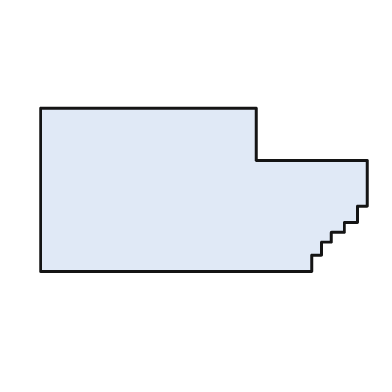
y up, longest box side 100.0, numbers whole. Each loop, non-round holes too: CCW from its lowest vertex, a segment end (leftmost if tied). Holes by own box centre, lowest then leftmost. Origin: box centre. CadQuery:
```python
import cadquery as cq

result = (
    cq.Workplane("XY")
    .moveTo(-50.0, -25.0)
    .lineTo(33.0, -25.0)
    .lineTo(33.0, -20.0)
    .lineTo(36.0, -20.0)
    .lineTo(36.0, -16.0)
    .lineTo(39.0, -16.0)
    .lineTo(39.0, -13.0)
    .lineTo(43.0, -13.0)
    .lineTo(43.0, -10.0)
    .lineTo(47.0, -10.0)
    .lineTo(47.0, -5.0)
    .lineTo(50.0, -5.0)
    .lineTo(50.0, 9.0)
    .lineTo(16.0, 9.0)
    .lineTo(16.0, 25.0)
    .lineTo(-50.0, 25.0)
    .close()
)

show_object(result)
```